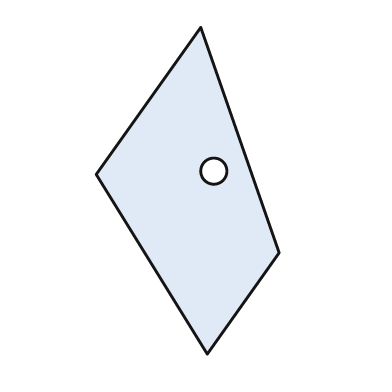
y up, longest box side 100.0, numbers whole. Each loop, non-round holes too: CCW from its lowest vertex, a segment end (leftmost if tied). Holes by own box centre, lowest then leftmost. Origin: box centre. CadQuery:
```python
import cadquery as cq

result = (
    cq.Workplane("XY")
    .moveTo(6.0, -50.0)
    .lineTo(28.0, -19.0)
    .lineTo(4.0, 50.0)
    .lineTo(-28.0, 5.0)
    .close()
    .moveTo(8.0, 6.0)
    .circle(4.0)
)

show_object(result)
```